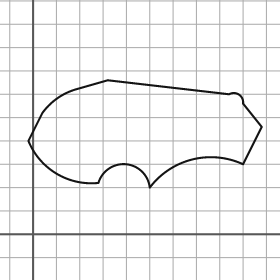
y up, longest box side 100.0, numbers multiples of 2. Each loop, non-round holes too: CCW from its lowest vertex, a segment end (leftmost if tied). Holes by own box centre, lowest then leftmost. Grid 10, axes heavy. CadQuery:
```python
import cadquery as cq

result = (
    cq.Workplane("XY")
    .moveTo(50.0, 20.0)
    .threePointArc((68.0, 32.0), (90.0, 30.0))
    .lineTo(98.0, 46.0)
    .lineTo(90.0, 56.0)
    .threePointArc((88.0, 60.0), (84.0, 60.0))
    .lineTo(32.0, 66.0)
    .lineTo(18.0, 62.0)
    .threePointArc((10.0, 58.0), (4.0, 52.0))
    .lineTo(-2.0, 40.0)
    .threePointArc((10.0, 26.0), (28.0, 22.0))
    .threePointArc((40.0, 30.0), (50.0, 20.0))
    .close()
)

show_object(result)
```